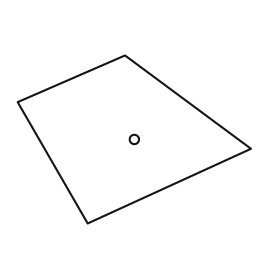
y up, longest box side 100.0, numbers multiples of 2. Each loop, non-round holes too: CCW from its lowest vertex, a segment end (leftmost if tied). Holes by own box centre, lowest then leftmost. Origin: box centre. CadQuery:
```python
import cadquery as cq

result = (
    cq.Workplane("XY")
    .moveTo(-20.0, -36.0)
    .lineTo(50.0, -4.0)
    .lineTo(-4.0, 36.0)
    .lineTo(-50.0, 16.0)
    .close()
    .moveTo(0.0, 0.0)
    .circle(2.0)
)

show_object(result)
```